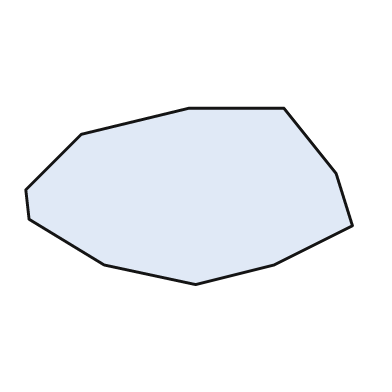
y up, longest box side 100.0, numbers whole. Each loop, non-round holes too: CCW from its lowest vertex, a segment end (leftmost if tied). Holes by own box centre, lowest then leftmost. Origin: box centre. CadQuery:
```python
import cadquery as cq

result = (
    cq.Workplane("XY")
    .moveTo(2.0, -27.0)
    .lineTo(26.0, -21.0)
    .lineTo(50.0, -9.0)
    .lineTo(45.0, 7.0)
    .lineTo(29.0, 27.0)
    .lineTo(0.0, 27.0)
    .lineTo(-33.0, 19.0)
    .lineTo(-50.0, 2.0)
    .lineTo(-49.0, -7.0)
    .lineTo(-26.0, -21.0)
    .close()
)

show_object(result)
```